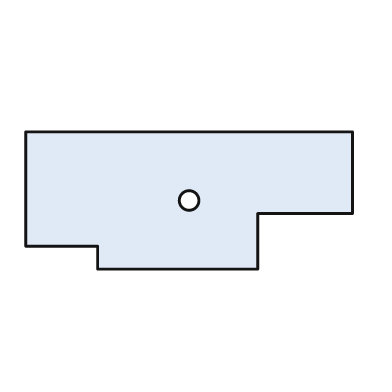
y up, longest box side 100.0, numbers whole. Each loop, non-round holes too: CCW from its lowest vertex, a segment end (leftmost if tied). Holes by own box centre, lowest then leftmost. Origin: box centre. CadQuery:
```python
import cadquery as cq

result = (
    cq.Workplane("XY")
    .moveTo(-28.0, -21.0)
    .lineTo(21.0, -21.0)
    .lineTo(21.0, -4.0)
    .lineTo(50.0, -4.0)
    .lineTo(50.0, 21.0)
    .lineTo(-50.0, 21.0)
    .lineTo(-50.0, -14.0)
    .lineTo(-28.0, -14.0)
    .close()
    .moveTo(0.0, 0.0)
    .circle(3.0)
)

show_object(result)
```